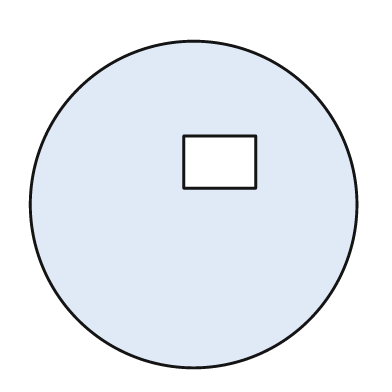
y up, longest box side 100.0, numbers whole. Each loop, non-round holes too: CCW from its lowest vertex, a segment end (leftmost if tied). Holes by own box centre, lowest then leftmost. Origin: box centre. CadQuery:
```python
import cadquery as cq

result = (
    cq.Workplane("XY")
    .moveTo(0.0, 0.0)
    .circle(50.0)
    .moveTo(-3.0, 5.0)
    .lineTo(19.0, 5.0)
    .lineTo(19.0, 21.0)
    .lineTo(-3.0, 21.0)
    .close()
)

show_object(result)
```